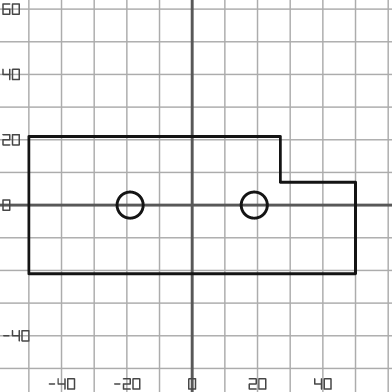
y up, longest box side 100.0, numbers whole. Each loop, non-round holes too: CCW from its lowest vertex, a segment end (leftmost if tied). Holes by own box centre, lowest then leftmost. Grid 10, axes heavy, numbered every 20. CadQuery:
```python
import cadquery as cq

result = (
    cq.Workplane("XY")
    .moveTo(-50.0, -21.0)
    .lineTo(50.0, -21.0)
    .lineTo(50.0, 7.0)
    .lineTo(27.0, 7.0)
    .lineTo(27.0, 21.0)
    .lineTo(-50.0, 21.0)
    .close()
    .moveTo(-19.0, 0.0)
    .circle(4.0)
    .moveTo(19.0, 0.0)
    .circle(4.0)
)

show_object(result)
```